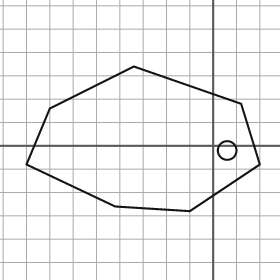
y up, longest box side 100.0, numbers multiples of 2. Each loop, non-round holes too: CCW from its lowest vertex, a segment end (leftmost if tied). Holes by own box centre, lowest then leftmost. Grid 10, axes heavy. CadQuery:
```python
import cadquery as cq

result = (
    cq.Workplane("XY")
    .moveTo(-10.0, -28.0)
    .lineTo(20.0, -8.0)
    .lineTo(12.0, 18.0)
    .lineTo(-34.0, 34.0)
    .lineTo(-70.0, 16.0)
    .lineTo(-80.0, -8.0)
    .lineTo(-42.0, -26.0)
    .close()
    .moveTo(6.0, -2.0)
    .circle(4.0)
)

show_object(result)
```